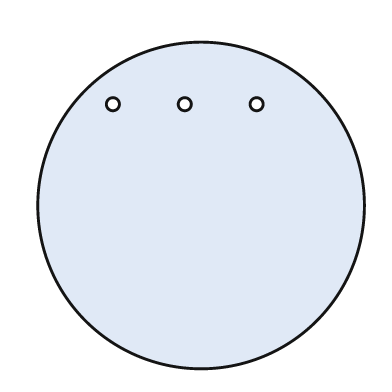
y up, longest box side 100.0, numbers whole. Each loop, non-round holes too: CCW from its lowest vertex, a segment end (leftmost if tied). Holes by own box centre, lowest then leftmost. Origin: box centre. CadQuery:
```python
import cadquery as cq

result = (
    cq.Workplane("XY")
    .moveTo(0.0, 0.0)
    .circle(50.0)
    .moveTo(-27.0, 31.0)
    .circle(2.0)
    .moveTo(-5.0, 31.0)
    .circle(2.0)
    .moveTo(17.0, 31.0)
    .circle(2.0)
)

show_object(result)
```